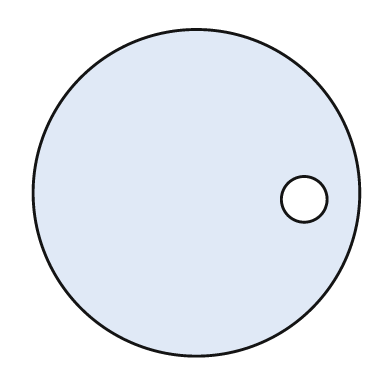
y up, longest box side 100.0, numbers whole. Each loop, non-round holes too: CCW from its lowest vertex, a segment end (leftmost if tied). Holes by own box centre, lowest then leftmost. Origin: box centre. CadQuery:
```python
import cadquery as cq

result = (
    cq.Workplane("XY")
    .moveTo(0.0, 0.0)
    .circle(50.0)
    .moveTo(33.0, -2.0)
    .circle(7.0)
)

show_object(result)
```